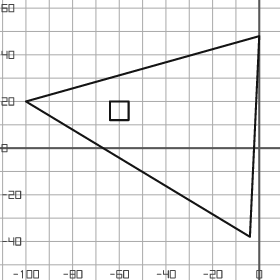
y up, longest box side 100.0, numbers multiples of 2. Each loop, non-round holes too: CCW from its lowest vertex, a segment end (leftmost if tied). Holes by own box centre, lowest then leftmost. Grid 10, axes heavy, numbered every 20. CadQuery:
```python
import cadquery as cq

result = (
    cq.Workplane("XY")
    .moveTo(-4.0, -38.0)
    .lineTo(0.0, 48.0)
    .lineTo(-100.0, 20.0)
    .close()
    .moveTo(-64.0, 12.0)
    .lineTo(-56.0, 12.0)
    .lineTo(-56.0, 20.0)
    .lineTo(-64.0, 20.0)
    .close()
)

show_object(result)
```